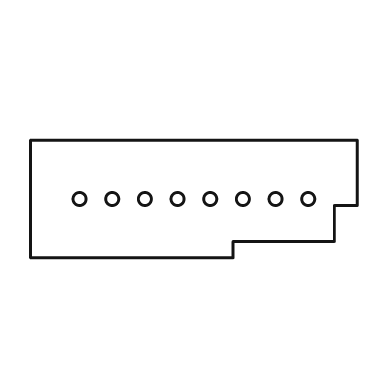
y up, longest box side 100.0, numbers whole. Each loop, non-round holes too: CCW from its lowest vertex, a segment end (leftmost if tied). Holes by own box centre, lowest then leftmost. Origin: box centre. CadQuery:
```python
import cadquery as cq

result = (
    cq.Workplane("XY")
    .moveTo(-50.0, -18.0)
    .lineTo(12.0, -18.0)
    .lineTo(12.0, -13.0)
    .lineTo(43.0, -13.0)
    .lineTo(43.0, -2.0)
    .lineTo(50.0, -2.0)
    .lineTo(50.0, 18.0)
    .lineTo(-50.0, 18.0)
    .close()
    .moveTo(-35.0, 0.0)
    .circle(2.0)
    .moveTo(-25.0, 0.0)
    .circle(2.0)
    .moveTo(-15.0, 0.0)
    .circle(2.0)
    .moveTo(-5.0, 0.0)
    .circle(2.0)
    .moveTo(5.0, 0.0)
    .circle(2.0)
    .moveTo(15.0, 0.0)
    .circle(2.0)
    .moveTo(25.0, 0.0)
    .circle(2.0)
    .moveTo(35.0, 0.0)
    .circle(2.0)
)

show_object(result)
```